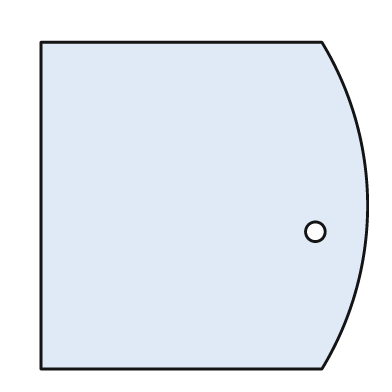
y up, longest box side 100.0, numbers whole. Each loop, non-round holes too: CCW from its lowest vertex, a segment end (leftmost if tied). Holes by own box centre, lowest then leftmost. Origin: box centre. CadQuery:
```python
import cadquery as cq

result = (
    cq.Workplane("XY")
    .moveTo(-50.0, -50.0)
    .lineTo(36.0, -50.0)
    .threePointArc((50.0, 0.0), (36.0, 50.0))
    .lineTo(-50.0, 50.0)
    .close()
    .moveTo(34.0, -8.0)
    .circle(3.0)
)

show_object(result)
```